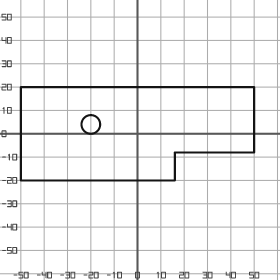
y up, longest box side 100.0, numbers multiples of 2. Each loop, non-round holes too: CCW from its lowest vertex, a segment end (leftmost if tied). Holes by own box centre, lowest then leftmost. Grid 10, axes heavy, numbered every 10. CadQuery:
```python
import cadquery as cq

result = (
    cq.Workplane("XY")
    .moveTo(-50.0, -20.0)
    .lineTo(16.0, -20.0)
    .lineTo(16.0, -8.0)
    .lineTo(50.0, -8.0)
    .lineTo(50.0, 20.0)
    .lineTo(-50.0, 20.0)
    .close()
    .moveTo(-20.0, 4.0)
    .circle(4.0)
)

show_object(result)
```